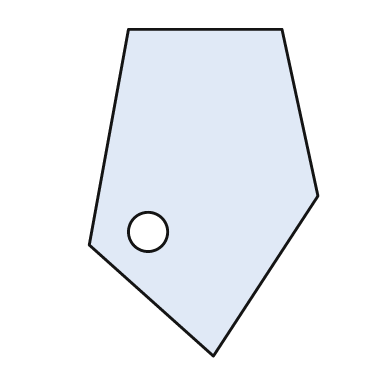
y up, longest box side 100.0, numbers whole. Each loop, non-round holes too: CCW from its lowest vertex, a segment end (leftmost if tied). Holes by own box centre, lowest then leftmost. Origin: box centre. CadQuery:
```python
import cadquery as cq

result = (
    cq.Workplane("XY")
    .moveTo(3.0, -50.0)
    .lineTo(35.0, -1.0)
    .lineTo(24.0, 50.0)
    .lineTo(-23.0, 50.0)
    .lineTo(-35.0, -16.0)
    .close()
    .moveTo(-17.0, -12.0)
    .circle(6.0)
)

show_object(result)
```